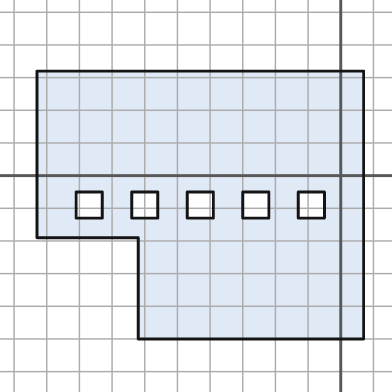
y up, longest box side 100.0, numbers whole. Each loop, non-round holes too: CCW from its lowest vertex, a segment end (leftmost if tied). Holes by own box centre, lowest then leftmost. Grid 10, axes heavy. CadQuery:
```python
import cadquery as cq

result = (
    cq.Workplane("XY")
    .moveTo(-62.0, -50.0)
    .lineTo(7.0, -50.0)
    .lineTo(7.0, 32.0)
    .lineTo(-93.0, 32.0)
    .lineTo(-93.0, -19.0)
    .lineTo(-62.0, -19.0)
    .close()
    .moveTo(-81.0, -13.0)
    .lineTo(-73.0, -13.0)
    .lineTo(-73.0, -5.0)
    .lineTo(-81.0, -5.0)
    .close()
    .moveTo(-64.0, -13.0)
    .lineTo(-56.0, -13.0)
    .lineTo(-56.0, -5.0)
    .lineTo(-64.0, -5.0)
    .close()
    .moveTo(-47.0, -13.0)
    .lineTo(-39.0, -13.0)
    .lineTo(-39.0, -5.0)
    .lineTo(-47.0, -5.0)
    .close()
    .moveTo(-30.0, -13.0)
    .lineTo(-22.0, -13.0)
    .lineTo(-22.0, -5.0)
    .lineTo(-30.0, -5.0)
    .close()
    .moveTo(-13.0, -13.0)
    .lineTo(-5.0, -13.0)
    .lineTo(-5.0, -5.0)
    .lineTo(-13.0, -5.0)
    .close()
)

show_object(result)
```